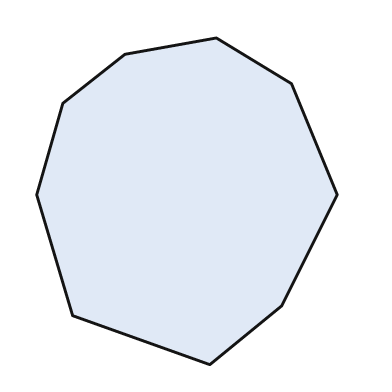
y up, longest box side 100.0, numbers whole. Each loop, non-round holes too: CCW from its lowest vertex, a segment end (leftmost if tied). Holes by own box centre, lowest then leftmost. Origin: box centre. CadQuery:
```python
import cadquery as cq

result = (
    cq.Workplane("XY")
    .moveTo(7.0, -50.0)
    .lineTo(29.0, -32.0)
    .lineTo(46.0, 2.0)
    .lineTo(32.0, 36.0)
    .lineTo(9.0, 50.0)
    .lineTo(-19.0, 45.0)
    .lineTo(-38.0, 30.0)
    .lineTo(-46.0, 2.0)
    .lineTo(-35.0, -35.0)
    .close()
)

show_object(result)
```